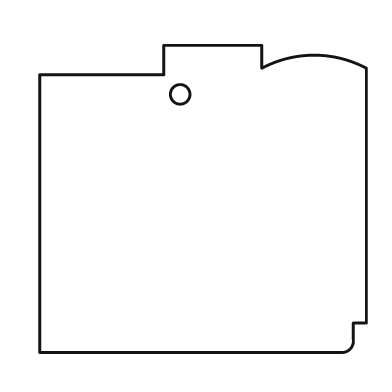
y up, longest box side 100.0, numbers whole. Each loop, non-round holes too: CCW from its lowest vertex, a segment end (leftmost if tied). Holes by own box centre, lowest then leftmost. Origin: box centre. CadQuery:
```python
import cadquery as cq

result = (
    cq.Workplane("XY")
    .moveTo(-50.0, -47.0)
    .lineTo(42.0, -47.0)
    .threePointArc((45.0, -46.0), (46.0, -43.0))
    .lineTo(46.0, -38.0)
    .lineTo(50.0, -38.0)
    .lineTo(50.0, 40.0)
    .threePointArc((34.0, 44.0), (18.0, 40.0))
    .lineTo(18.0, 47.0)
    .lineTo(-12.0, 47.0)
    .lineTo(-12.0, 38.0)
    .lineTo(-50.0, 38.0)
    .close()
    .moveTo(-7.0, 32.0)
    .circle(3.0)
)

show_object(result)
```